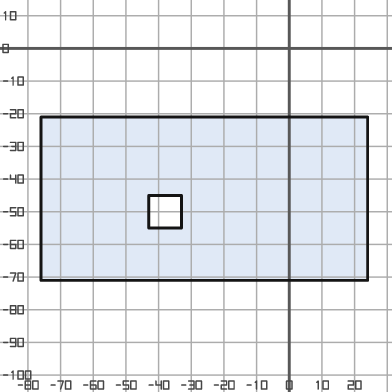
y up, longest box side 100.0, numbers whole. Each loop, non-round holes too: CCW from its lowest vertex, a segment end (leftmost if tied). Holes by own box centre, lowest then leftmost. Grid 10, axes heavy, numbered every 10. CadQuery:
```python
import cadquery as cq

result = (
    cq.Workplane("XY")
    .moveTo(-76.0, -71.0)
    .lineTo(24.0, -71.0)
    .lineTo(24.0, -21.0)
    .lineTo(-76.0, -21.0)
    .close()
    .moveTo(-43.0, -55.0)
    .lineTo(-33.0, -55.0)
    .lineTo(-33.0, -45.0)
    .lineTo(-43.0, -45.0)
    .close()
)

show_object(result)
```